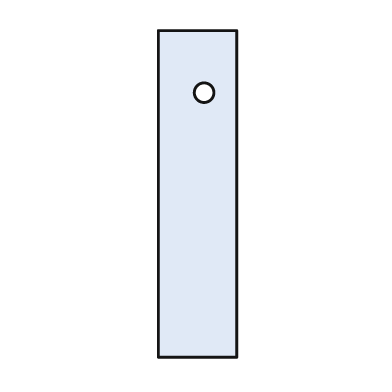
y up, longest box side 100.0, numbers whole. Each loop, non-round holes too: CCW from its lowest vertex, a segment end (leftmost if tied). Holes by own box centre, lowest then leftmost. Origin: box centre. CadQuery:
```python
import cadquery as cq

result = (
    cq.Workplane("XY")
    .moveTo(-12.0, -50.0)
    .lineTo(12.0, -50.0)
    .lineTo(12.0, 50.0)
    .lineTo(-12.0, 50.0)
    .close()
    .moveTo(2.0, 31.0)
    .circle(3.0)
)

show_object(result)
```